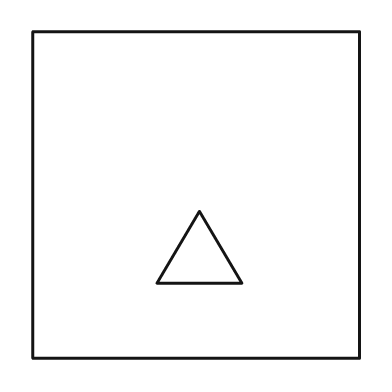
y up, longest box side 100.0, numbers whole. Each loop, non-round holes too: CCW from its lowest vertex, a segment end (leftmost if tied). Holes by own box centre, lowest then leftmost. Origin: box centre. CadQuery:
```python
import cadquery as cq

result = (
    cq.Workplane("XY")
    .moveTo(-50.0, -50.0)
    .lineTo(50.0, -50.0)
    .lineTo(50.0, 50.0)
    .lineTo(-50.0, 50.0)
    .close()
    .moveTo(-12.0, -27.0)
    .lineTo(14.0, -27.0)
    .lineTo(1.0, -5.0)
    .close()
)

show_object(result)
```